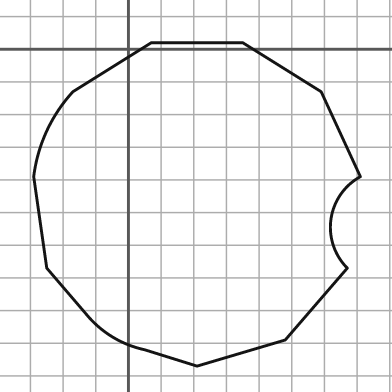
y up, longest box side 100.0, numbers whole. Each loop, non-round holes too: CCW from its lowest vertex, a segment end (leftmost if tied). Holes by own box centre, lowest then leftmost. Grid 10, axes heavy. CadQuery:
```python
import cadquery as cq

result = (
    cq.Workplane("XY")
    .moveTo(21.0, -97.0)
    .lineTo(48.0, -89.0)
    .lineTo(67.0, -67.0)
    .threePointArc((62.0, -52.0), (71.0, -39.0))
    .lineTo(59.0, -13.0)
    .lineTo(35.0, 2.0)
    .lineTo(7.0, 2.0)
    .lineTo(-17.0, -13.0)
    .threePointArc((-25.0, -25.0), (-29.0, -39.0))
    .lineTo(-25.0, -67.0)
    .lineTo(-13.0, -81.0)
    .threePointArc((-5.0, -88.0), (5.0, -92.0))
    .close()
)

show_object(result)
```